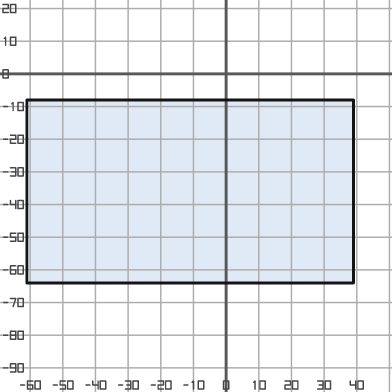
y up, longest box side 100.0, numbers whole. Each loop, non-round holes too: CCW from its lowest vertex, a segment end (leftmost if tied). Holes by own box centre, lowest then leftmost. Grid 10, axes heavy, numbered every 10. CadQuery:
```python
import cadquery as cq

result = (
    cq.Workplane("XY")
    .moveTo(-61.0, -64.0)
    .lineTo(39.0, -64.0)
    .lineTo(39.0, -8.0)
    .lineTo(-61.0, -8.0)
    .close()
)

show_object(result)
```